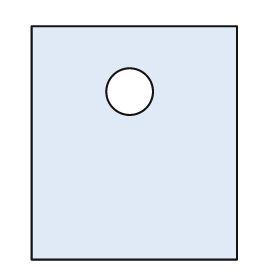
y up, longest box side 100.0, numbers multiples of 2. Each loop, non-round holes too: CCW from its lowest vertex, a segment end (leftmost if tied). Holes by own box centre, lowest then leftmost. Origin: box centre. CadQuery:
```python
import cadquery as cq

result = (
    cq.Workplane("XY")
    .moveTo(-44.0, -50.0)
    .lineTo(44.0, -50.0)
    .lineTo(44.0, 50.0)
    .lineTo(-44.0, 50.0)
    .close()
    .moveTo(-2.0, 22.0)
    .circle(10.0)
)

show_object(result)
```